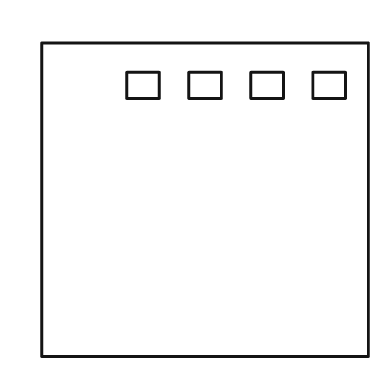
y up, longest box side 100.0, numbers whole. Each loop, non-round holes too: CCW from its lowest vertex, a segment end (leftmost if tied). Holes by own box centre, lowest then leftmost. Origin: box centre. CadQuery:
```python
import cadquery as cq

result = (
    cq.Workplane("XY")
    .moveTo(-50.0, -48.0)
    .lineTo(50.0, -48.0)
    .lineTo(50.0, 48.0)
    .lineTo(-50.0, 48.0)
    .close()
    .moveTo(-24.0, 31.0)
    .lineTo(-14.0, 31.0)
    .lineTo(-14.0, 39.0)
    .lineTo(-24.0, 39.0)
    .close()
    .moveTo(-5.0, 31.0)
    .lineTo(5.0, 31.0)
    .lineTo(5.0, 39.0)
    .lineTo(-5.0, 39.0)
    .close()
    .moveTo(14.0, 31.0)
    .lineTo(24.0, 31.0)
    .lineTo(24.0, 39.0)
    .lineTo(14.0, 39.0)
    .close()
    .moveTo(33.0, 31.0)
    .lineTo(43.0, 31.0)
    .lineTo(43.0, 39.0)
    .lineTo(33.0, 39.0)
    .close()
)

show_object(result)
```